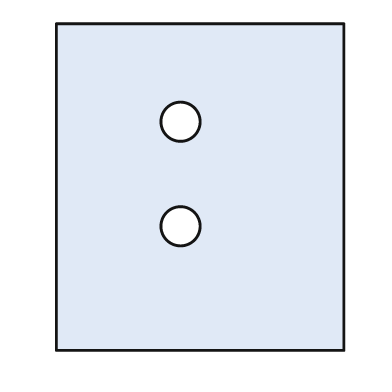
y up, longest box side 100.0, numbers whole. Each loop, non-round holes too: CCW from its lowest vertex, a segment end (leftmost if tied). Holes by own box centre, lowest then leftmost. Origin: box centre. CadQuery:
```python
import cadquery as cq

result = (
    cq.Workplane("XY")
    .moveTo(-44.0, -50.0)
    .lineTo(44.0, -50.0)
    .lineTo(44.0, 50.0)
    .lineTo(-44.0, 50.0)
    .close()
    .moveTo(-6.0, -12.0)
    .circle(6.0)
    .moveTo(-6.0, 20.0)
    .circle(6.0)
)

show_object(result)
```